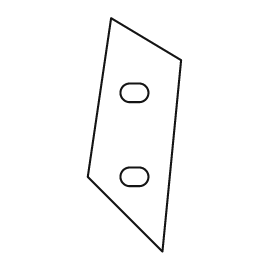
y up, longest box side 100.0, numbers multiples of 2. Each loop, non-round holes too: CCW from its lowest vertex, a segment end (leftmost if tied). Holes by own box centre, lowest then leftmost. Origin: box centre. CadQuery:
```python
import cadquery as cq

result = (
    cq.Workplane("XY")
    .moveTo(12.0, -50.0)
    .lineTo(20.0, 32.0)
    .lineTo(-10.0, 50.0)
    .lineTo(-20.0, -18.0)
    .close()
    .moveTo(-2.0, -22.0)
    .lineTo(2.0, -22.0)
    .threePointArc((6.0, -18.0), (2.0, -14.0))
    .lineTo(-2.0, -14.0)
    .threePointArc((-6.0, -18.0), (-2.0, -22.0))
    .close()
    .moveTo(-2.0, 14.0)
    .lineTo(2.0, 14.0)
    .threePointArc((6.0, 18.0), (2.0, 22.0))
    .lineTo(-2.0, 22.0)
    .threePointArc((-6.0, 18.0), (-2.0, 14.0))
    .close()
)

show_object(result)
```